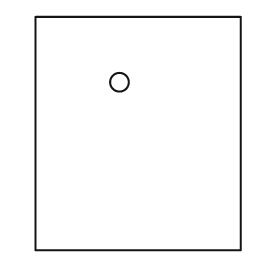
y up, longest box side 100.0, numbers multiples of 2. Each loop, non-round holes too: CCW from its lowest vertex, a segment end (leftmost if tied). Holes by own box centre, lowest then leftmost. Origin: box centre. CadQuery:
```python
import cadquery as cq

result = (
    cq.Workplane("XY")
    .moveTo(-44.0, -50.0)
    .lineTo(44.0, -50.0)
    .lineTo(44.0, 50.0)
    .lineTo(-44.0, 50.0)
    .close()
    .moveTo(-8.0, 22.0)
    .circle(4.0)
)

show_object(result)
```